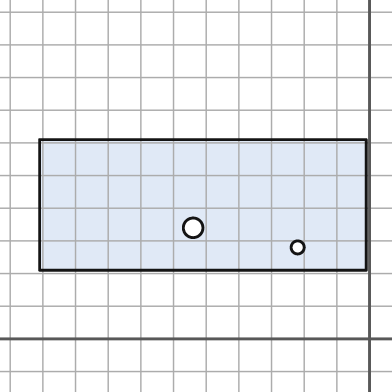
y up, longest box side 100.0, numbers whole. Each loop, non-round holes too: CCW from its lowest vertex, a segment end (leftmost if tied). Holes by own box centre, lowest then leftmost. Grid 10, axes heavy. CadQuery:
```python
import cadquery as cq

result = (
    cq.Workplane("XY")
    .moveTo(-101.0, 21.0)
    .lineTo(-1.0, 21.0)
    .lineTo(-1.0, 61.0)
    .lineTo(-101.0, 61.0)
    .close()
    .moveTo(-22.0, 28.0)
    .circle(2.0)
    .moveTo(-54.0, 34.0)
    .circle(3.0)
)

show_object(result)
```